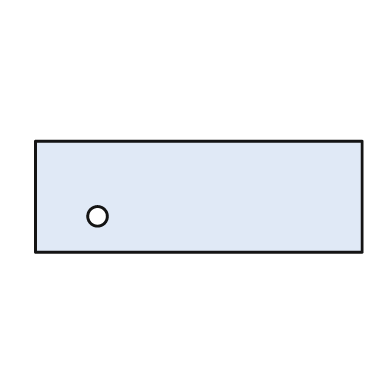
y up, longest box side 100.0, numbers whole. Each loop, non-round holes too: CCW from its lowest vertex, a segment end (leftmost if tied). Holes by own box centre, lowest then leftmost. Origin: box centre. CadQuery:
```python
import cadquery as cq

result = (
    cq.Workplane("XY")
    .moveTo(-50.0, -17.0)
    .lineTo(50.0, -17.0)
    .lineTo(50.0, 17.0)
    .lineTo(-50.0, 17.0)
    .close()
    .moveTo(-31.0, -6.0)
    .circle(3.0)
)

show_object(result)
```